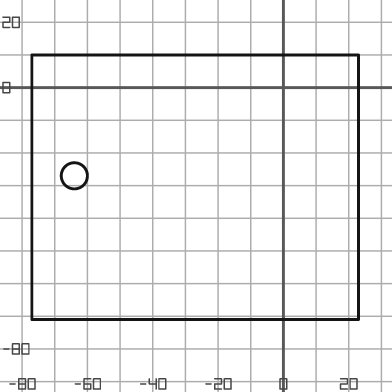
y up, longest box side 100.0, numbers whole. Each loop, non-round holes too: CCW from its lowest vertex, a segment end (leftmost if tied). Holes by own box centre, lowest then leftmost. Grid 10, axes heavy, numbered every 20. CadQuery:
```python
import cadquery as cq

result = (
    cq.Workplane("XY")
    .moveTo(-77.0, -71.0)
    .lineTo(23.0, -71.0)
    .lineTo(23.0, 10.0)
    .lineTo(-77.0, 10.0)
    .close()
    .moveTo(-64.0, -27.0)
    .circle(4.0)
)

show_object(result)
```